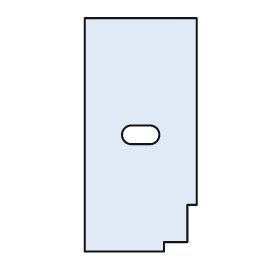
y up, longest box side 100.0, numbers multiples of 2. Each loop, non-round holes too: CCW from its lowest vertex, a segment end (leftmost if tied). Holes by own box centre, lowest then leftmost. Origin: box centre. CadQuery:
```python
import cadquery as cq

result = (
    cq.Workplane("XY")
    .moveTo(-24.0, -50.0)
    .lineTo(10.0, -50.0)
    .lineTo(10.0, -46.0)
    .lineTo(20.0, -46.0)
    .lineTo(20.0, -30.0)
    .lineTo(24.0, -30.0)
    .lineTo(24.0, 50.0)
    .lineTo(-24.0, 50.0)
    .close()
    .moveTo(-4.0, -4.0)
    .lineTo(4.0, -4.0)
    .threePointArc((8.0, 0.0), (4.0, 4.0))
    .lineTo(-4.0, 4.0)
    .threePointArc((-8.0, 0.0), (-4.0, -4.0))
    .close()
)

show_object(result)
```